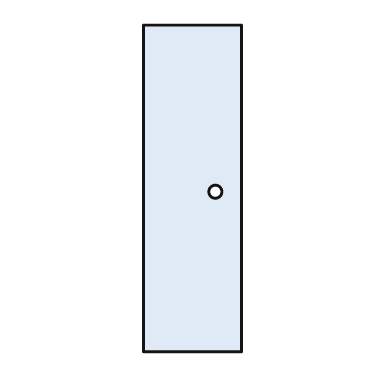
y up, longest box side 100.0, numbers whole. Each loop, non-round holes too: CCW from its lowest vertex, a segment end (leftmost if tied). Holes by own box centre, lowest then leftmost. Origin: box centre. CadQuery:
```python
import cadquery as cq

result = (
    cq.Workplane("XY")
    .moveTo(-15.0, -50.0)
    .lineTo(15.0, -50.0)
    .lineTo(15.0, 50.0)
    .lineTo(-15.0, 50.0)
    .close()
    .moveTo(7.0, -1.0)
    .circle(2.0)
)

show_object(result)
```